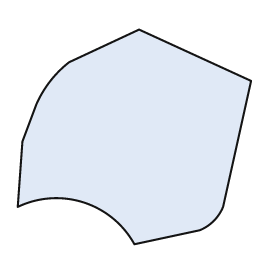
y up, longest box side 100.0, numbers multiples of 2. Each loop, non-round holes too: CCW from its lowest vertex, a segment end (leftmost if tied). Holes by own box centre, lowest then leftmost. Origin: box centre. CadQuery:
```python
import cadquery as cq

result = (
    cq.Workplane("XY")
    .moveTo(0.0, -46.0)
    .lineTo(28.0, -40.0)
    .threePointArc((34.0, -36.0), (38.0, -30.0))
    .lineTo(50.0, 24.0)
    .lineTo(2.0, 46.0)
    .lineTo(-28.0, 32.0)
    .threePointArc((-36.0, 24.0), (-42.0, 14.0))
    .lineTo(-48.0, -2.0)
    .lineTo(-50.0, -30.0)
    .threePointArc((-22.0, -28.0), (0.0, -46.0))
    .close()
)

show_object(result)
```